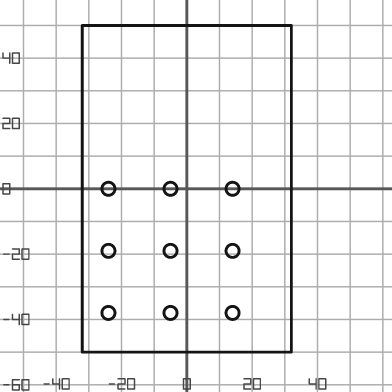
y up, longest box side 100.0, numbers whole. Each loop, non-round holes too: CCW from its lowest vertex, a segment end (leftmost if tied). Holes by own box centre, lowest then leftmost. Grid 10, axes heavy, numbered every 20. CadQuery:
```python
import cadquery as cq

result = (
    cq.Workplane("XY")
    .moveTo(-32.0, -50.0)
    .lineTo(32.0, -50.0)
    .lineTo(32.0, 50.0)
    .lineTo(-32.0, 50.0)
    .close()
    .moveTo(-24.0, -38.0)
    .circle(2.0)
    .moveTo(-5.0, -38.0)
    .circle(2.0)
    .moveTo(14.0, -38.0)
    .circle(2.0)
    .moveTo(-24.0, -19.0)
    .circle(2.0)
    .moveTo(-5.0, -19.0)
    .circle(2.0)
    .moveTo(14.0, -19.0)
    .circle(2.0)
    .moveTo(-24.0, 0.0)
    .circle(2.0)
    .moveTo(-5.0, 0.0)
    .circle(2.0)
    .moveTo(14.0, 0.0)
    .circle(2.0)
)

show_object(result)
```